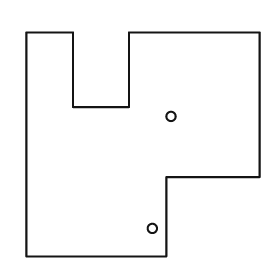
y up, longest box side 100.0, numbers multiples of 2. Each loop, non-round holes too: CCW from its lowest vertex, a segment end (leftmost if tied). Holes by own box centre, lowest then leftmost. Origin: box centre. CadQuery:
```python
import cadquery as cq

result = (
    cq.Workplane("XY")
    .moveTo(-50.0, -48.0)
    .lineTo(10.0, -48.0)
    .lineTo(10.0, -14.0)
    .lineTo(50.0, -14.0)
    .lineTo(50.0, 48.0)
    .lineTo(-6.0, 48.0)
    .lineTo(-6.0, 16.0)
    .lineTo(-30.0, 16.0)
    .lineTo(-30.0, 48.0)
    .lineTo(-50.0, 48.0)
    .close()
    .moveTo(4.0, -36.0)
    .circle(2.0)
    .moveTo(12.0, 12.0)
    .circle(2.0)
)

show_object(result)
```